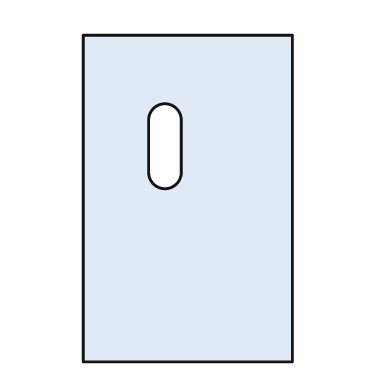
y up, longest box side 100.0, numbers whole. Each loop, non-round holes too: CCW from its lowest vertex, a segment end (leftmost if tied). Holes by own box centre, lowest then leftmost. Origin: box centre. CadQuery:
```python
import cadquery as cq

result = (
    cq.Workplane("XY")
    .moveTo(-32.0, -50.0)
    .lineTo(32.0, -50.0)
    .lineTo(32.0, 50.0)
    .lineTo(-32.0, 50.0)
    .close()
    .moveTo(-12.0, 8.0)
    .threePointArc((-7.0, 3.0), (-2.0, 8.0))
    .lineTo(-2.0, 24.0)
    .threePointArc((-7.0, 29.0), (-12.0, 24.0))
    .close()
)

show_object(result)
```